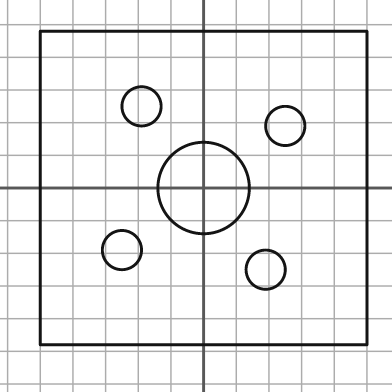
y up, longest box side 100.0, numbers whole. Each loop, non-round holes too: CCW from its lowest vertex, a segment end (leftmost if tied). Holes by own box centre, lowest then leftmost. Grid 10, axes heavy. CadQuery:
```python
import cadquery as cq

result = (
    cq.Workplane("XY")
    .moveTo(-50.0, -48.0)
    .lineTo(50.0, -48.0)
    .lineTo(50.0, 48.0)
    .lineTo(-50.0, 48.0)
    .close()
    .moveTo(19.0, -25.0)
    .circle(6.0)
    .moveTo(-25.0, -19.0)
    .circle(6.0)
    .moveTo(0.0, 0.0)
    .circle(14.0)
    .moveTo(25.0, 19.0)
    .circle(6.0)
    .moveTo(-19.0, 25.0)
    .circle(6.0)
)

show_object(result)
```